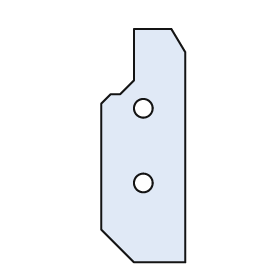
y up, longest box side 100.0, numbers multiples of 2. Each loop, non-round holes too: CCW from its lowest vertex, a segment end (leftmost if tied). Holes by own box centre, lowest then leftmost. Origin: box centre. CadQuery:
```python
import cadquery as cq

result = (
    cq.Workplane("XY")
    .moveTo(-4.0, -50.0)
    .lineTo(18.0, -50.0)
    .lineTo(18.0, 40.0)
    .lineTo(12.0, 50.0)
    .lineTo(-4.0, 50.0)
    .lineTo(-4.0, 28.0)
    .lineTo(-10.0, 22.0)
    .lineTo(-14.0, 22.0)
    .lineTo(-18.0, 18.0)
    .lineTo(-18.0, -36.0)
    .close()
    .moveTo(0.0, -16.0)
    .circle(4.0)
    .moveTo(0.0, 16.0)
    .circle(4.0)
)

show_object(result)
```